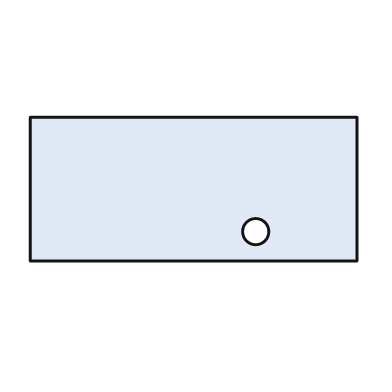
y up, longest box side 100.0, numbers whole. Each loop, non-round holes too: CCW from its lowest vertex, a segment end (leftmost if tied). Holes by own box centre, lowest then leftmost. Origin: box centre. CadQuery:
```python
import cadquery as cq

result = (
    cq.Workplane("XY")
    .moveTo(-50.0, -22.0)
    .lineTo(50.0, -22.0)
    .lineTo(50.0, 22.0)
    .lineTo(-50.0, 22.0)
    .close()
    .moveTo(19.0, -13.0)
    .circle(4.0)
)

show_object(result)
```